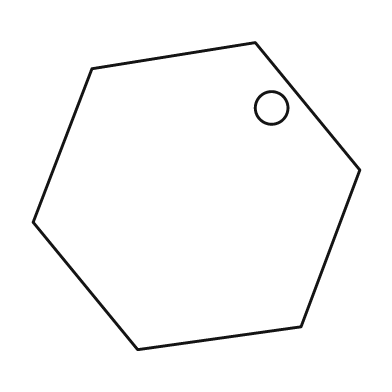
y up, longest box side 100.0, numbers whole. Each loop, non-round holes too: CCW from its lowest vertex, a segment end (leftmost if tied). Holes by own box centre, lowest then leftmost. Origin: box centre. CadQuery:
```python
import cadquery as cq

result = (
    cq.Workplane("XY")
    .moveTo(-18.0, -47.0)
    .lineTo(32.0, -40.0)
    .lineTo(50.0, 8.0)
    .lineTo(18.0, 47.0)
    .lineTo(-32.0, 39.0)
    .lineTo(-50.0, -8.0)
    .close()
    .moveTo(23.0, 27.0)
    .circle(5.0)
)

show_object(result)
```